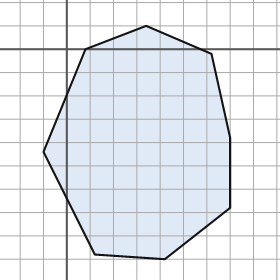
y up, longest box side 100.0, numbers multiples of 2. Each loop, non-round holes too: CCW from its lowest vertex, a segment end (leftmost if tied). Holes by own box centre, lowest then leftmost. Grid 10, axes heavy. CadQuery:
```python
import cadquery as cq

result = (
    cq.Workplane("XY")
    .moveTo(42.0, -90.0)
    .lineTo(70.0, -68.0)
    .lineTo(70.0, -38.0)
    .lineTo(62.0, -2.0)
    .lineTo(34.0, 10.0)
    .lineTo(8.0, 0.0)
    .lineTo(-10.0, -44.0)
    .lineTo(12.0, -88.0)
    .close()
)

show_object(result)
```